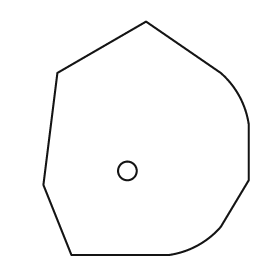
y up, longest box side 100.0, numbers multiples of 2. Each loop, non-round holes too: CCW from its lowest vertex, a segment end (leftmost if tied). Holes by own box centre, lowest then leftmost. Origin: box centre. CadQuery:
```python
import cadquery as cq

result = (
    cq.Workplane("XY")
    .moveTo(-32.0, -50.0)
    .lineTo(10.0, -50.0)
    .threePointArc((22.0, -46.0), (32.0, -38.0))
    .lineTo(44.0, -18.0)
    .lineTo(44.0, 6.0)
    .threePointArc((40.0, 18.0), (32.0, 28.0))
    .lineTo(0.0, 50.0)
    .lineTo(-38.0, 28.0)
    .lineTo(-44.0, -20.0)
    .close()
    .moveTo(-8.0, -14.0)
    .circle(4.0)
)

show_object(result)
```